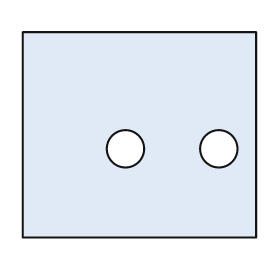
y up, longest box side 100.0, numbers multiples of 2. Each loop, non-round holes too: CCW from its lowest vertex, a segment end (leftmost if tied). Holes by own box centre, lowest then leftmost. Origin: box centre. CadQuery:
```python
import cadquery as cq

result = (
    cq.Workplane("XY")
    .moveTo(-50.0, -44.0)
    .lineTo(50.0, -44.0)
    .lineTo(50.0, 44.0)
    .lineTo(-50.0, 44.0)
    .close()
    .moveTo(-6.0, -6.0)
    .circle(8.0)
    .moveTo(34.0, -6.0)
    .circle(8.0)
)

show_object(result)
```